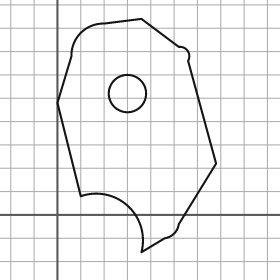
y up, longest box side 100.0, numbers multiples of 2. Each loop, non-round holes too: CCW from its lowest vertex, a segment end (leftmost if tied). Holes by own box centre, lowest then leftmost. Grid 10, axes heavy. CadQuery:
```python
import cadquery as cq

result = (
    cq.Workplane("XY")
    .moveTo(36.0, -16.0)
    .lineTo(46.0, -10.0)
    .threePointArc((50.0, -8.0), (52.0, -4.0))
    .lineTo(68.0, 22.0)
    .lineTo(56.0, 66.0)
    .threePointArc((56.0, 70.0), (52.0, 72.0))
    .lineTo(36.0, 84.0)
    .lineTo(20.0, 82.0)
    .threePointArc((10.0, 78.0), (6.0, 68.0))
    .lineTo(0.0, 48.0)
    .lineTo(10.0, 8.0)
    .threePointArc((30.0, 4.0), (36.0, -16.0))
    .close()
    .moveTo(30.0, 52.0)
    .circle(8.0)
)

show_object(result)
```